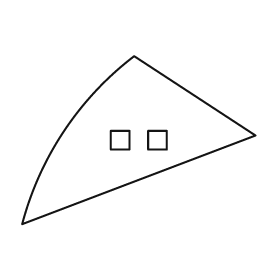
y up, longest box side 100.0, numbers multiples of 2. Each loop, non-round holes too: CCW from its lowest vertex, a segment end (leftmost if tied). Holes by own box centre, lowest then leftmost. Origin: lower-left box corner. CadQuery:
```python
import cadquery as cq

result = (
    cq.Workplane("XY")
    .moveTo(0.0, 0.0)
    .lineTo(100.0, 38.0)
    .lineTo(48.0, 72.0)
    .threePointArc((18.0, 40.0), (0.0, 0.0))
    .close()
    .moveTo(38.0, 32.0)
    .lineTo(46.0, 32.0)
    .lineTo(46.0, 40.0)
    .lineTo(38.0, 40.0)
    .close()
    .moveTo(54.0, 32.0)
    .lineTo(62.0, 32.0)
    .lineTo(62.0, 40.0)
    .lineTo(54.0, 40.0)
    .close()
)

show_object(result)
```